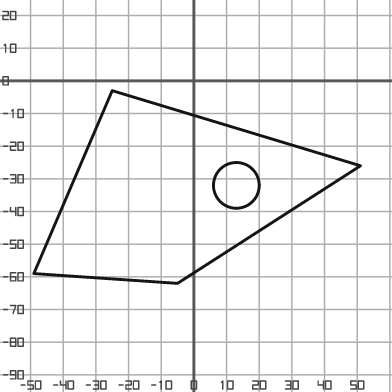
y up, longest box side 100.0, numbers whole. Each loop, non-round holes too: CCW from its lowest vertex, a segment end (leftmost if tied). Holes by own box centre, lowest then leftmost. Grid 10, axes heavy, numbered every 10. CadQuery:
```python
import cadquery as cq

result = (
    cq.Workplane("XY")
    .moveTo(-5.0, -62.0)
    .lineTo(51.0, -26.0)
    .lineTo(-25.0, -3.0)
    .lineTo(-49.0, -59.0)
    .close()
    .moveTo(13.0, -32.0)
    .circle(7.0)
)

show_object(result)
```